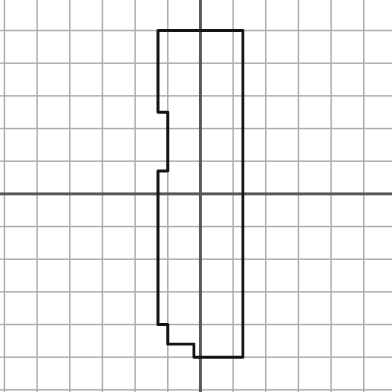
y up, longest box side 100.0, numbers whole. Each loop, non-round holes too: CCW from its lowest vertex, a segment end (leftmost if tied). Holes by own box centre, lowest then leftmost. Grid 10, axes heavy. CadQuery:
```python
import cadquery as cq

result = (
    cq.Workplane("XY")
    .moveTo(-2.0, -50.0)
    .lineTo(13.0, -50.0)
    .lineTo(13.0, 50.0)
    .lineTo(-13.0, 50.0)
    .lineTo(-13.0, 25.0)
    .lineTo(-10.0, 25.0)
    .lineTo(-10.0, 7.0)
    .lineTo(-13.0, 7.0)
    .lineTo(-13.0, -40.0)
    .lineTo(-10.0, -40.0)
    .lineTo(-10.0, -46.0)
    .lineTo(-2.0, -46.0)
    .close()
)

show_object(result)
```